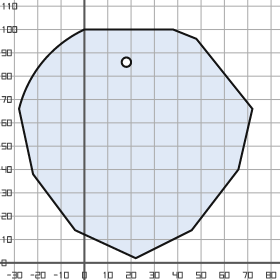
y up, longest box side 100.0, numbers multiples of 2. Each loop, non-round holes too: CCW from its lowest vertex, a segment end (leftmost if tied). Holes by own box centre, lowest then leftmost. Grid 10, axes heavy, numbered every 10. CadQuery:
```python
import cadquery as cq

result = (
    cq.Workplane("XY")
    .moveTo(22.0, 2.0)
    .lineTo(46.0, 14.0)
    .lineTo(66.0, 40.0)
    .lineTo(72.0, 66.0)
    .lineTo(48.0, 96.0)
    .lineTo(38.0, 100.0)
    .lineTo(0.0, 100.0)
    .threePointArc((-18.0, 86.0), (-28.0, 66.0))
    .lineTo(-22.0, 38.0)
    .lineTo(-4.0, 14.0)
    .close()
    .moveTo(18.0, 86.0)
    .circle(2.0)
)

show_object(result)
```